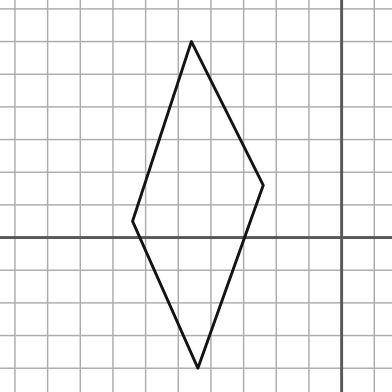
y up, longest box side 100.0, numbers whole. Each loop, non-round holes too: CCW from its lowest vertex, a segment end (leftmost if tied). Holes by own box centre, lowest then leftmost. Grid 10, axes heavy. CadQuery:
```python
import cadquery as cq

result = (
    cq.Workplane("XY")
    .moveTo(-44.0, -40.0)
    .lineTo(-24.0, 16.0)
    .lineTo(-46.0, 60.0)
    .lineTo(-64.0, 5.0)
    .close()
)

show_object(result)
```